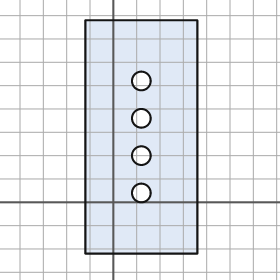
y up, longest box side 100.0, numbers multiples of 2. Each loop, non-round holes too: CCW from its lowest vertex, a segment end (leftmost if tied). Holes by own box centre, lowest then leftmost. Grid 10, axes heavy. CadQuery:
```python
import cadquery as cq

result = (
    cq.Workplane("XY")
    .moveTo(-12.0, -22.0)
    .lineTo(36.0, -22.0)
    .lineTo(36.0, 78.0)
    .lineTo(-12.0, 78.0)
    .close()
    .moveTo(12.0, 4.0)
    .circle(4.0)
    .moveTo(12.0, 20.0)
    .circle(4.0)
    .moveTo(12.0, 36.0)
    .circle(4.0)
    .moveTo(12.0, 52.0)
    .circle(4.0)
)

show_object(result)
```